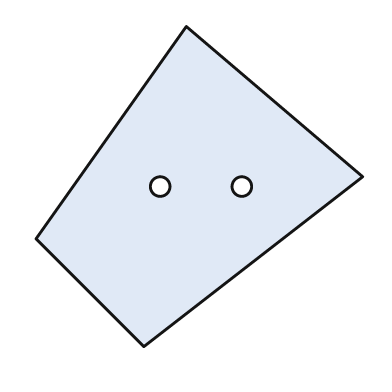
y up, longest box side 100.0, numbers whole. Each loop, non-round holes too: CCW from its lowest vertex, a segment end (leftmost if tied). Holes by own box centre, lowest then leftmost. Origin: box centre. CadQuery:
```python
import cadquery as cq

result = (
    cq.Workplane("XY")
    .moveTo(-17.0, -49.0)
    .lineTo(50.0, 3.0)
    .lineTo(-4.0, 49.0)
    .lineTo(-50.0, -16.0)
    .close()
    .moveTo(-12.0, 0.0)
    .circle(3.0)
    .moveTo(13.0, 0.0)
    .circle(3.0)
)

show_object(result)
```